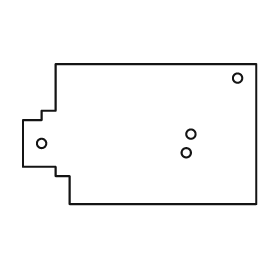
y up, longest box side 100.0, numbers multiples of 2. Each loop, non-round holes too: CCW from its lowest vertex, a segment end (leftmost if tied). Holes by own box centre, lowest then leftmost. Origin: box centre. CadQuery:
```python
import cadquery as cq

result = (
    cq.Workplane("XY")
    .moveTo(-30.0, -30.0)
    .lineTo(50.0, -30.0)
    .lineTo(50.0, 30.0)
    .lineTo(-36.0, 30.0)
    .lineTo(-36.0, 10.0)
    .lineTo(-42.0, 10.0)
    .lineTo(-42.0, 6.0)
    .lineTo(-50.0, 6.0)
    .lineTo(-50.0, -14.0)
    .lineTo(-36.0, -14.0)
    .lineTo(-36.0, -18.0)
    .lineTo(-30.0, -18.0)
    .close()
    .moveTo(20.0, -8.0)
    .circle(2.0)
    .moveTo(-42.0, -4.0)
    .circle(2.0)
    .moveTo(22.0, 0.0)
    .circle(2.0)
    .moveTo(42.0, 24.0)
    .circle(2.0)
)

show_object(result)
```